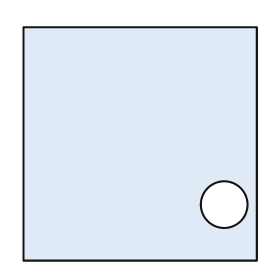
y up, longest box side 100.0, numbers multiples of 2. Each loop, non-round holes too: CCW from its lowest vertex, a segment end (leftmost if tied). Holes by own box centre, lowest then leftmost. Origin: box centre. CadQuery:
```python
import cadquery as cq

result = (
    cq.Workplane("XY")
    .moveTo(-50.0, -50.0)
    .lineTo(50.0, -50.0)
    .lineTo(50.0, 50.0)
    .lineTo(-50.0, 50.0)
    .close()
    .moveTo(36.0, -26.0)
    .circle(10.0)
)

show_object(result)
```